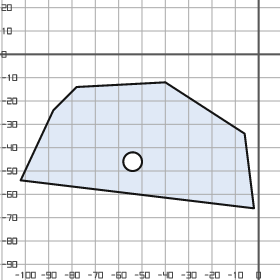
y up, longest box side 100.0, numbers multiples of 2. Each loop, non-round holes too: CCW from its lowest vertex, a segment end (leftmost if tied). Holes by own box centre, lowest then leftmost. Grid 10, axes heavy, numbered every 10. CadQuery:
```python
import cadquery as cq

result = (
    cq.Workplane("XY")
    .moveTo(-2.0, -66.0)
    .lineTo(-6.0, -34.0)
    .lineTo(-40.0, -12.0)
    .lineTo(-78.0, -14.0)
    .lineTo(-88.0, -24.0)
    .lineTo(-102.0, -54.0)
    .close()
    .moveTo(-54.0, -46.0)
    .circle(4.0)
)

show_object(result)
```